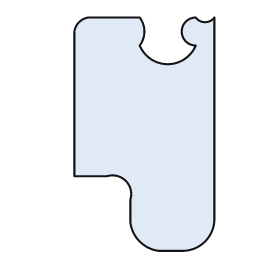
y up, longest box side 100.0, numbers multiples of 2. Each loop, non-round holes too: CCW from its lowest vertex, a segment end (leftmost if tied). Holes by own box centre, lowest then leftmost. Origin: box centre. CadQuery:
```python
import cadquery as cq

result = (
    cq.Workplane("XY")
    .moveTo(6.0, -50.0)
    .lineTo(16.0, -50.0)
    .threePointArc((26.0, -46.0), (30.0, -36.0))
    .lineTo(30.0, 50.0)
    .threePointArc((26.0, 48.0), (22.0, 50.0))
    .threePointArc((16.0, 44.0), (22.0, 38.0))
    .threePointArc((10.0, 30.0), (-2.0, 38.0))
    .threePointArc((0.0, 44.0), (-2.0, 50.0))
    .lineTo(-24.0, 50.0)
    .threePointArc((-28.0, 48.0), (-30.0, 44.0))
    .lineTo(-30.0, -18.0)
    .lineTo(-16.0, -18.0)
    .threePointArc((-8.0, -20.0), (-6.0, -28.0))
    .lineTo(-6.0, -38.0)
    .threePointArc((-2.0, -46.0), (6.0, -50.0))
    .close()
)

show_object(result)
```